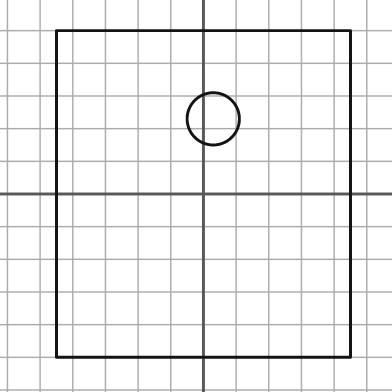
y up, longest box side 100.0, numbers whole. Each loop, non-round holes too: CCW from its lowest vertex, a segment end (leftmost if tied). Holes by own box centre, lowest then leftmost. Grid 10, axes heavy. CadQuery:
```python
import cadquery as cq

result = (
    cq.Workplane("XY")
    .moveTo(-45.0, -50.0)
    .lineTo(45.0, -50.0)
    .lineTo(45.0, 50.0)
    .lineTo(-45.0, 50.0)
    .close()
    .moveTo(3.0, 23.0)
    .circle(8.0)
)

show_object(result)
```